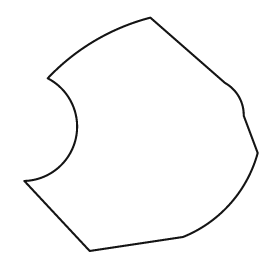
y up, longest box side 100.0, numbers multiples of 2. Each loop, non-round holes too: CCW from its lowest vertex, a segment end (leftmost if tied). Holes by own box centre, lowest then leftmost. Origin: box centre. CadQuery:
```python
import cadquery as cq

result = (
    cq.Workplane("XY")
    .moveTo(-22.0, -50.0)
    .lineTo(18.0, -44.0)
    .threePointArc((38.0, -30.0), (50.0, -8.0))
    .lineTo(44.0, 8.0)
    .threePointArc((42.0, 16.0), (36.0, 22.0))
    .lineTo(4.0, 50.0)
    .threePointArc((-20.0, 40.0), (-40.0, 24.0))
    .threePointArc((-28.0, -2.0), (-50.0, -20.0))
    .close()
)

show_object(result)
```